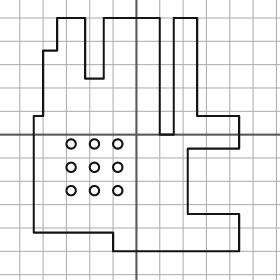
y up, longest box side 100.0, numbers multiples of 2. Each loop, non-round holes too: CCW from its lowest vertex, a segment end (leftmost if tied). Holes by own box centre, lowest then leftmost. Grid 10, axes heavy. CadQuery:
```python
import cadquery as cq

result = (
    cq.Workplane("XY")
    .moveTo(-10.0, -50.0)
    .lineTo(44.0, -50.0)
    .lineTo(44.0, -34.0)
    .lineTo(22.0, -34.0)
    .lineTo(22.0, -6.0)
    .lineTo(44.0, -6.0)
    .lineTo(44.0, 8.0)
    .lineTo(26.0, 8.0)
    .lineTo(26.0, 50.0)
    .lineTo(16.0, 50.0)
    .lineTo(16.0, 0.0)
    .lineTo(10.0, 0.0)
    .lineTo(10.0, 50.0)
    .lineTo(-14.0, 50.0)
    .lineTo(-14.0, 24.0)
    .lineTo(-22.0, 24.0)
    .lineTo(-22.0, 50.0)
    .lineTo(-34.0, 50.0)
    .lineTo(-34.0, 36.0)
    .lineTo(-40.0, 36.0)
    .lineTo(-40.0, 8.0)
    .lineTo(-44.0, 8.0)
    .lineTo(-44.0, -42.0)
    .lineTo(-10.0, -42.0)
    .close()
    .moveTo(-28.0, -24.0)
    .circle(2.0)
    .moveTo(-18.0, -24.0)
    .circle(2.0)
    .moveTo(-8.0, -24.0)
    .circle(2.0)
    .moveTo(-28.0, -14.0)
    .circle(2.0)
    .moveTo(-18.0, -14.0)
    .circle(2.0)
    .moveTo(-8.0, -14.0)
    .circle(2.0)
    .moveTo(-28.0, -4.0)
    .circle(2.0)
    .moveTo(-18.0, -4.0)
    .circle(2.0)
    .moveTo(-8.0, -4.0)
    .circle(2.0)
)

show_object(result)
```